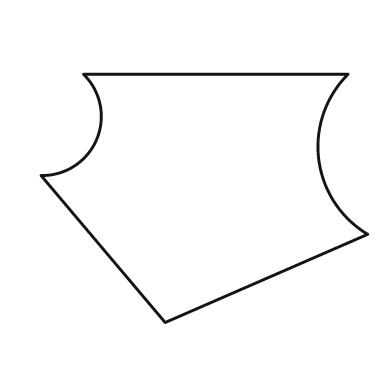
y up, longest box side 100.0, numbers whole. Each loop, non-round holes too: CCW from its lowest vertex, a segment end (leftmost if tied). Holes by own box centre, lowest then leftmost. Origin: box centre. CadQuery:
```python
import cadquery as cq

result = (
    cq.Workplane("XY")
    .moveTo(-12.0, -38.0)
    .lineTo(50.0, -11.0)
    .threePointArc((35.0, 12.0), (44.0, 38.0))
    .lineTo(-37.0, 38.0)
    .threePointArc((-33.0, 18.0), (-50.0, 7.0))
    .close()
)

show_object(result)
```